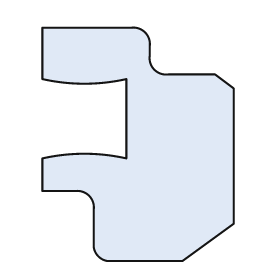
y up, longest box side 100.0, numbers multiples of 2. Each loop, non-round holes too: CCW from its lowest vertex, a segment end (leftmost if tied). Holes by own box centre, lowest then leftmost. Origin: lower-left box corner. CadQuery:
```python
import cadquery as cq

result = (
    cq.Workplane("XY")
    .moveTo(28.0, 0.0)
    .lineTo(60.0, 0.0)
    .lineTo(82.0, 16.0)
    .lineTo(82.0, 74.0)
    .lineTo(74.0, 80.0)
    .lineTo(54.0, 80.0)
    .threePointArc((48.0, 82.0), (46.0, 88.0))
    .lineTo(46.0, 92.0)
    .threePointArc((44.0, 98.0), (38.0, 100.0))
    .lineTo(0.0, 100.0)
    .lineTo(0.0, 78.0)
    .threePointArc((18.0, 76.0), (36.0, 78.0))
    .lineTo(36.0, 44.0)
    .threePointArc((18.0, 46.0), (0.0, 44.0))
    .lineTo(0.0, 30.0)
    .lineTo(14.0, 30.0)
    .threePointArc((20.0, 28.0), (22.0, 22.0))
    .lineTo(22.0, 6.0)
    .threePointArc((24.0, 2.0), (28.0, 0.0))
    .close()
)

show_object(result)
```